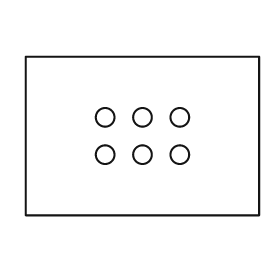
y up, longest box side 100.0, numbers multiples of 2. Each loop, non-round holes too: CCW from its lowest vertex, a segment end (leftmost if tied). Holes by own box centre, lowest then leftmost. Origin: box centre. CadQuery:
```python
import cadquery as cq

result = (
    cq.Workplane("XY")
    .moveTo(-50.0, -34.0)
    .lineTo(50.0, -34.0)
    .lineTo(50.0, 34.0)
    .lineTo(-50.0, 34.0)
    .close()
    .moveTo(-16.0, -8.0)
    .circle(4.0)
    .moveTo(0.0, -8.0)
    .circle(4.0)
    .moveTo(16.0, -8.0)
    .circle(4.0)
    .moveTo(-16.0, 8.0)
    .circle(4.0)
    .moveTo(0.0, 8.0)
    .circle(4.0)
    .moveTo(16.0, 8.0)
    .circle(4.0)
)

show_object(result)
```